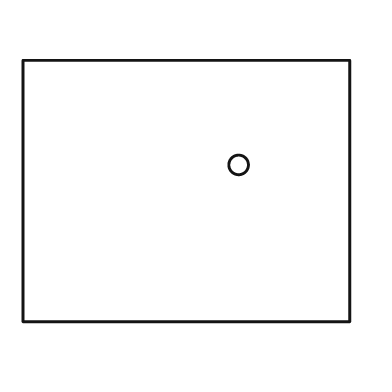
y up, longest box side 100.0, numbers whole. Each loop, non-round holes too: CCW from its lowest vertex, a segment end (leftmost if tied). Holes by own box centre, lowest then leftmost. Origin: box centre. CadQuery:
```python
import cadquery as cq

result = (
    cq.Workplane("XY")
    .moveTo(-50.0, -40.0)
    .lineTo(50.0, -40.0)
    .lineTo(50.0, 40.0)
    .lineTo(-50.0, 40.0)
    .close()
    .moveTo(16.0, 8.0)
    .circle(3.0)
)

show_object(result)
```